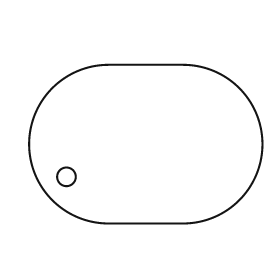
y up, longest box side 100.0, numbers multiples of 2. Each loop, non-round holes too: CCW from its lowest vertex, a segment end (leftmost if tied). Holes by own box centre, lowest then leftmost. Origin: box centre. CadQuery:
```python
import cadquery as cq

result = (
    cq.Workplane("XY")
    .moveTo(-16.0, -34.0)
    .lineTo(16.0, -34.0)
    .threePointArc((50.0, 0.0), (16.0, 34.0))
    .lineTo(-16.0, 34.0)
    .threePointArc((-50.0, 0.0), (-16.0, -34.0))
    .close()
    .moveTo(-34.0, -14.0)
    .circle(4.0)
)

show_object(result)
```